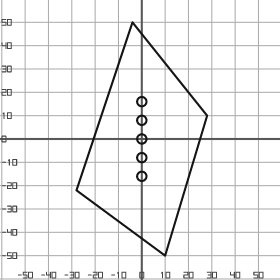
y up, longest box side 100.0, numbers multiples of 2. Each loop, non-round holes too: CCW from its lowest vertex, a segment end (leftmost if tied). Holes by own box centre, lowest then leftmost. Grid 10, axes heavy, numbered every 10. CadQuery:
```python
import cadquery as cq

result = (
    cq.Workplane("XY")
    .moveTo(10.0, -50.0)
    .lineTo(28.0, 10.0)
    .lineTo(-4.0, 50.0)
    .lineTo(-28.0, -22.0)
    .close()
    .moveTo(0.0, -16.0)
    .circle(2.0)
    .moveTo(0.0, -8.0)
    .circle(2.0)
    .moveTo(0.0, 0.0)
    .circle(2.0)
    .moveTo(0.0, 8.0)
    .circle(2.0)
    .moveTo(0.0, 16.0)
    .circle(2.0)
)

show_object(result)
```